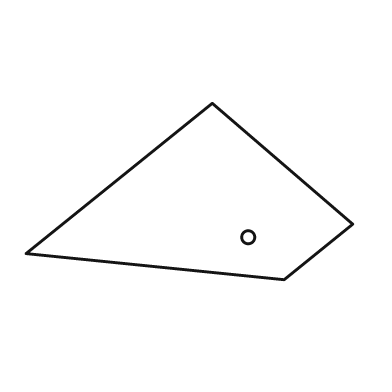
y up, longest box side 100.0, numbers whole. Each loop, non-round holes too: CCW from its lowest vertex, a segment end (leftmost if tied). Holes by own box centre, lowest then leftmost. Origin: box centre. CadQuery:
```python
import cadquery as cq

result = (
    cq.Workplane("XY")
    .moveTo(29.0, -27.0)
    .lineTo(50.0, -10.0)
    .lineTo(7.0, 27.0)
    .lineTo(-50.0, -19.0)
    .close()
    .moveTo(18.0, -14.0)
    .circle(2.0)
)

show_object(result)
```